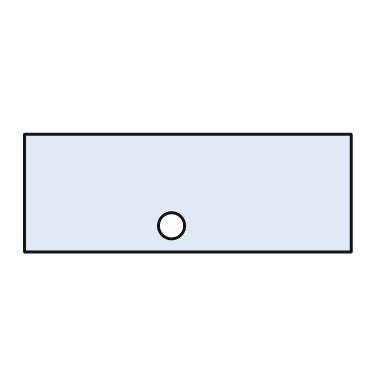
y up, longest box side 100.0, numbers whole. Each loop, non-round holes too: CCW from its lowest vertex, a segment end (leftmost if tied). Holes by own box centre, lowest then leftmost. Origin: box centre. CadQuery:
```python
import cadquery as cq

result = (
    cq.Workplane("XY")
    .moveTo(-50.0, -18.0)
    .lineTo(50.0, -18.0)
    .lineTo(50.0, 18.0)
    .lineTo(-50.0, 18.0)
    .close()
    .moveTo(-5.0, -10.0)
    .circle(4.0)
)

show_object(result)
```